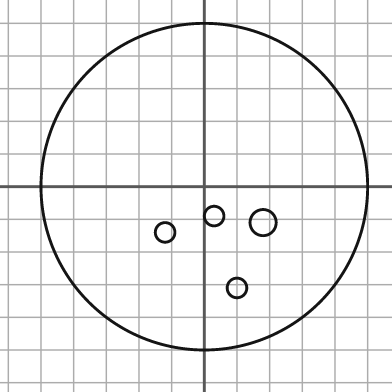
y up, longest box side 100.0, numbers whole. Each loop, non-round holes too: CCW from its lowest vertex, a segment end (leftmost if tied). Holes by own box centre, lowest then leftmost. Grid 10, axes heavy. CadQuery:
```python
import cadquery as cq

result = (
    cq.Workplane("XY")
    .moveTo(0.0, 0.0)
    .circle(50.0)
    .moveTo(10.0, -31.0)
    .circle(3.0)
    .moveTo(-12.0, -14.0)
    .circle(3.0)
    .moveTo(18.0, -11.0)
    .circle(4.0)
    .moveTo(3.0, -9.0)
    .circle(3.0)
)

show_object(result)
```